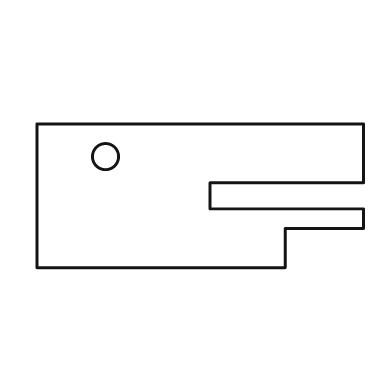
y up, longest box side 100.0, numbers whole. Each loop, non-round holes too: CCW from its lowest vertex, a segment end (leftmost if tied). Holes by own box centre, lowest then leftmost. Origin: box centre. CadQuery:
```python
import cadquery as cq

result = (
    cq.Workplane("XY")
    .moveTo(-50.0, -22.0)
    .lineTo(26.0, -22.0)
    .lineTo(26.0, -10.0)
    .lineTo(50.0, -10.0)
    .lineTo(50.0, -4.0)
    .lineTo(3.0, -4.0)
    .lineTo(3.0, 4.0)
    .lineTo(50.0, 4.0)
    .lineTo(50.0, 22.0)
    .lineTo(-50.0, 22.0)
    .close()
    .moveTo(-29.0, 12.0)
    .circle(4.0)
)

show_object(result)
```